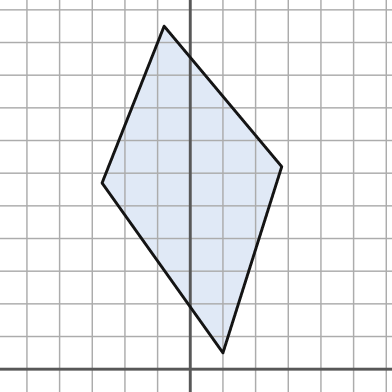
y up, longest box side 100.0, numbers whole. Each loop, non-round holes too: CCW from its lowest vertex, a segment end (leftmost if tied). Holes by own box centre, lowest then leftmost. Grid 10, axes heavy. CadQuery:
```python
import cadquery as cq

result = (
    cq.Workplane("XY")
    .moveTo(10.0, 5.0)
    .lineTo(28.0, 62.0)
    .lineTo(-8.0, 105.0)
    .lineTo(-27.0, 57.0)
    .close()
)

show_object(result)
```